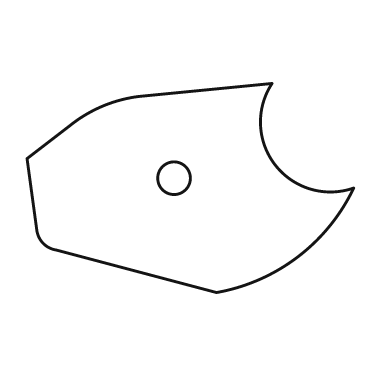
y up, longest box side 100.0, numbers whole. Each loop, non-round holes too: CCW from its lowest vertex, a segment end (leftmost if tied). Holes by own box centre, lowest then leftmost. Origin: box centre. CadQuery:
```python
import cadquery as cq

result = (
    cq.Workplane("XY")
    .moveTo(8.0, -32.0)
    .threePointArc((33.0, -21.0), (50.0, 0.0))
    .threePointArc((26.0, 7.0), (25.0, 32.0))
    .lineTo(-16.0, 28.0)
    .threePointArc((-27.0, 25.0), (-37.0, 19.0))
    .lineTo(-50.0, 9.0)
    .lineTo(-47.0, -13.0)
    .threePointArc((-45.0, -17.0), (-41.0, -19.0))
    .close()
    .moveTo(-5.0, 3.0)
    .circle(5.0)
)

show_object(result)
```